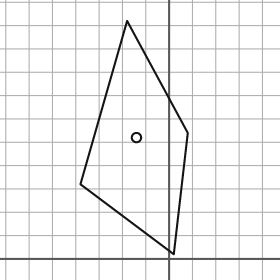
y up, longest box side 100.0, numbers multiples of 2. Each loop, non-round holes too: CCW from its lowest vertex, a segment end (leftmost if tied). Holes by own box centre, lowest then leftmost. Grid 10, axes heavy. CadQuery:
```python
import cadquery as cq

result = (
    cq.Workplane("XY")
    .moveTo(2.0, 2.0)
    .lineTo(8.0, 54.0)
    .lineTo(-18.0, 102.0)
    .lineTo(-38.0, 32.0)
    .close()
    .moveTo(-14.0, 52.0)
    .circle(2.0)
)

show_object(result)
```